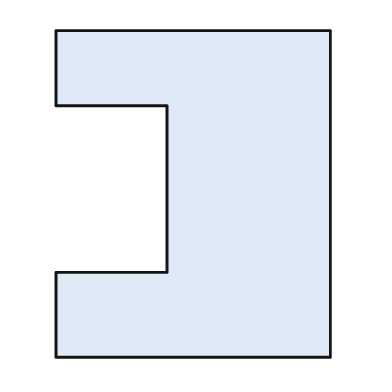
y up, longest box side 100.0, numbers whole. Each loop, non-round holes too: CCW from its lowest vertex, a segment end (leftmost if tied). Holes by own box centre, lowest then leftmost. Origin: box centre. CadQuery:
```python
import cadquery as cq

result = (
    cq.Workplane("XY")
    .moveTo(-42.0, -50.0)
    .lineTo(42.0, -50.0)
    .lineTo(42.0, 50.0)
    .lineTo(-42.0, 50.0)
    .lineTo(-42.0, 27.0)
    .lineTo(-8.0, 27.0)
    .lineTo(-8.0, -24.0)
    .lineTo(-42.0, -24.0)
    .close()
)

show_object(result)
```